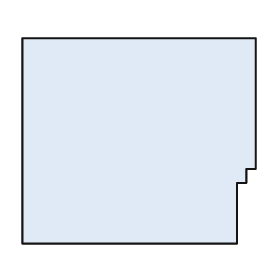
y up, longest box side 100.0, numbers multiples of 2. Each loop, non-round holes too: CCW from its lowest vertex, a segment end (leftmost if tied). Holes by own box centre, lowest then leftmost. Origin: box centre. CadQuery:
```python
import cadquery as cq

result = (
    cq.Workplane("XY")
    .moveTo(-50.0, -44.0)
    .lineTo(42.0, -44.0)
    .lineTo(42.0, -18.0)
    .lineTo(46.0, -18.0)
    .lineTo(46.0, -12.0)
    .lineTo(50.0, -12.0)
    .lineTo(50.0, 44.0)
    .lineTo(-50.0, 44.0)
    .close()
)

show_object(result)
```